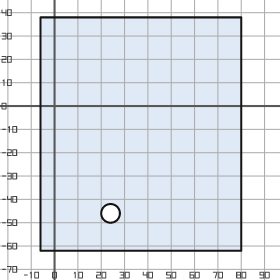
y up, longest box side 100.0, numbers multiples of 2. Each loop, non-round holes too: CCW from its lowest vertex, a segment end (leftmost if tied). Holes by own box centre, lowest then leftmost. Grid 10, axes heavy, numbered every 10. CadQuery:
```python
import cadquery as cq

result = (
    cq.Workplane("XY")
    .moveTo(-6.0, -62.0)
    .lineTo(80.0, -62.0)
    .lineTo(80.0, 38.0)
    .lineTo(-6.0, 38.0)
    .close()
    .moveTo(24.0, -46.0)
    .circle(4.0)
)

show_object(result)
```